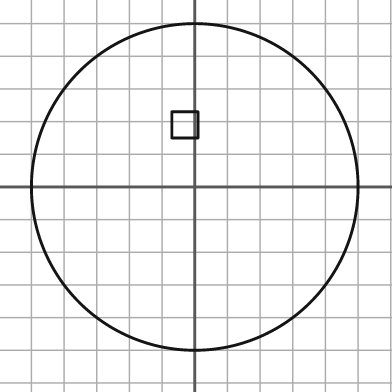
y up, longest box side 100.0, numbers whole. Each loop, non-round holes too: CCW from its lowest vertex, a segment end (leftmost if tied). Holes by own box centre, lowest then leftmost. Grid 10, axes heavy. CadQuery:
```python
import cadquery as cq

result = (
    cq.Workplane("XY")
    .moveTo(0.0, 0.0)
    .circle(50.0)
    .moveTo(-7.0, 15.0)
    .lineTo(1.0, 15.0)
    .lineTo(1.0, 23.0)
    .lineTo(-7.0, 23.0)
    .close()
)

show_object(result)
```